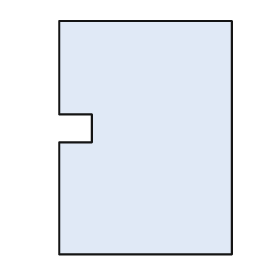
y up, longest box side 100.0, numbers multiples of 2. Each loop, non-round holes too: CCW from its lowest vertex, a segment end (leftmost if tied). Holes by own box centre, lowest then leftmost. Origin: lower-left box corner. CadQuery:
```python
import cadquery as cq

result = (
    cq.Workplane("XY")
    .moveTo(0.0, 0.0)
    .lineTo(74.0, 0.0)
    .lineTo(74.0, 100.0)
    .lineTo(0.0, 100.0)
    .lineTo(0.0, 60.0)
    .lineTo(14.0, 60.0)
    .lineTo(14.0, 48.0)
    .lineTo(0.0, 48.0)
    .close()
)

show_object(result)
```